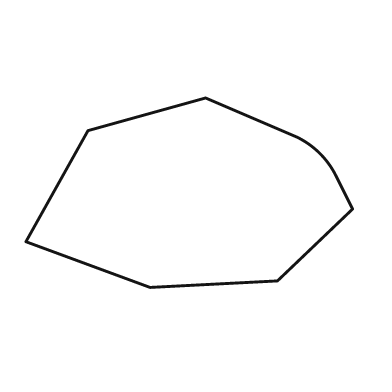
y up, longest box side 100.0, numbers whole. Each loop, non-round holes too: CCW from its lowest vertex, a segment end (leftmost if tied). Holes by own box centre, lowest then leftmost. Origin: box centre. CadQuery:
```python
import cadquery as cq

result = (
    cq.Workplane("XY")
    .moveTo(-12.0, -29.0)
    .lineTo(27.0, -27.0)
    .lineTo(50.0, -5.0)
    .lineTo(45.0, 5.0)
    .threePointArc((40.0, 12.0), (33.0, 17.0))
    .lineTo(5.0, 29.0)
    .lineTo(-31.0, 19.0)
    .lineTo(-50.0, -15.0)
    .close()
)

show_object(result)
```